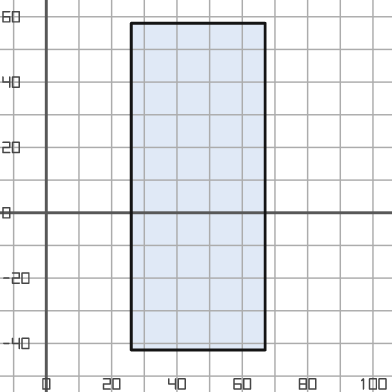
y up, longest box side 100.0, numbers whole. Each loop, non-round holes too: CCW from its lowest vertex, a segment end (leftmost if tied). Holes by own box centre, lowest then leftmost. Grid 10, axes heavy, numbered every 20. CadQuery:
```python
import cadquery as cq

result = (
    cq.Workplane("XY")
    .moveTo(26.0, -42.0)
    .lineTo(67.0, -42.0)
    .lineTo(67.0, 58.0)
    .lineTo(26.0, 58.0)
    .close()
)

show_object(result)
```